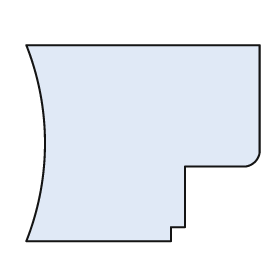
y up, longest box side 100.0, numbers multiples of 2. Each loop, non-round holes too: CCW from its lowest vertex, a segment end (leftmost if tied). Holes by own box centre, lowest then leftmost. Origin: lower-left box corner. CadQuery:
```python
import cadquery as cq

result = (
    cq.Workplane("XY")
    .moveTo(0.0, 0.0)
    .lineTo(62.0, 0.0)
    .lineTo(62.0, 6.0)
    .lineTo(68.0, 6.0)
    .lineTo(68.0, 32.0)
    .lineTo(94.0, 32.0)
    .threePointArc((98.0, 34.0), (100.0, 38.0))
    .lineTo(100.0, 84.0)
    .lineTo(0.0, 84.0)
    .threePointArc((8.0, 42.0), (0.0, 0.0))
    .close()
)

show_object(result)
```